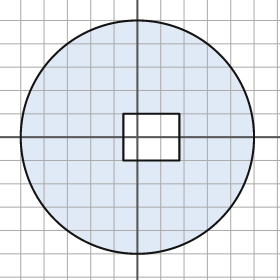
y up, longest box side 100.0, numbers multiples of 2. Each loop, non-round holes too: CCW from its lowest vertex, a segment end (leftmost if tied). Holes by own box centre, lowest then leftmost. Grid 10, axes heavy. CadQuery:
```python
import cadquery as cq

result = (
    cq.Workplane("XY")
    .moveTo(0.0, 0.0)
    .circle(50.0)
    .moveTo(-6.0, -10.0)
    .lineTo(18.0, -10.0)
    .lineTo(18.0, 10.0)
    .lineTo(-6.0, 10.0)
    .close()
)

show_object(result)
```